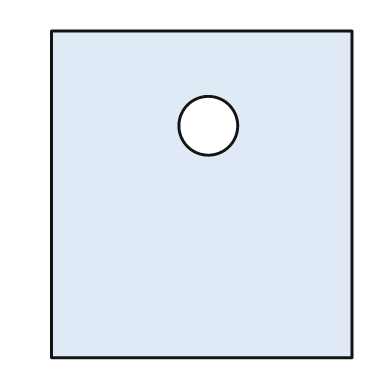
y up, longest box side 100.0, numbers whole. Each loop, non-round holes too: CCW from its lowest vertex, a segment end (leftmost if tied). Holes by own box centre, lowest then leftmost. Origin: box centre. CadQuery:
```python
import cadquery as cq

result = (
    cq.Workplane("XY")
    .moveTo(-46.0, -50.0)
    .lineTo(46.0, -50.0)
    .lineTo(46.0, 50.0)
    .lineTo(-46.0, 50.0)
    .close()
    .moveTo(2.0, 21.0)
    .circle(9.0)
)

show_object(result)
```